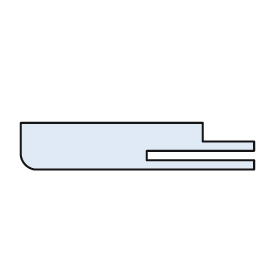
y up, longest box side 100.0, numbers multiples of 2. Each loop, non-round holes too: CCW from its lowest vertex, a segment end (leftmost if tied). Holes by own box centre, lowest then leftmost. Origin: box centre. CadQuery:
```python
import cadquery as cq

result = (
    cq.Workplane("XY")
    .moveTo(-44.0, -10.0)
    .lineTo(50.0, -10.0)
    .lineTo(50.0, -6.0)
    .lineTo(4.0, -6.0)
    .lineTo(4.0, -2.0)
    .lineTo(50.0, -2.0)
    .lineTo(50.0, 2.0)
    .lineTo(28.0, 2.0)
    .lineTo(28.0, 10.0)
    .lineTo(-50.0, 10.0)
    .lineTo(-50.0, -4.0)
    .threePointArc((-48.0, -8.0), (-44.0, -10.0))
    .close()
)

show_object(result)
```